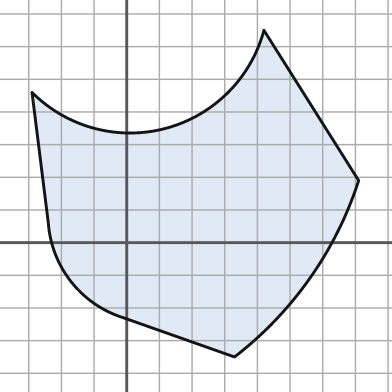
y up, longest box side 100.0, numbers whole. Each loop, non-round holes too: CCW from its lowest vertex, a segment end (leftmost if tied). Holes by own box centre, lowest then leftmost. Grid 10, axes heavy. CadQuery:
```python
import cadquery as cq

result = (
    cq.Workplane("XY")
    .moveTo(33.0, -35.0)
    .threePointArc((56.0, -11.0), (71.0, 19.0))
    .lineTo(42.0, 65.0)
    .threePointArc((12.0, 35.0), (-29.0, 46.0))
    .lineTo(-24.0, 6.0)
    .threePointArc((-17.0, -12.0), (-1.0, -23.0))
    .close()
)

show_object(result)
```